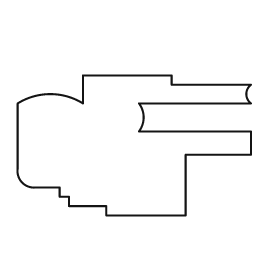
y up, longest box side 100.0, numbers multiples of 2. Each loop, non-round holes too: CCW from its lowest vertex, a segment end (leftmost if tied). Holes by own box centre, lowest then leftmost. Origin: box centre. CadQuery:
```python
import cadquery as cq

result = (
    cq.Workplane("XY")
    .moveTo(-12.0, -30.0)
    .lineTo(22.0, -30.0)
    .lineTo(22.0, -4.0)
    .lineTo(50.0, -4.0)
    .lineTo(50.0, 6.0)
    .lineTo(2.0, 6.0)
    .threePointArc((4.0, 12.0), (2.0, 18.0))
    .lineTo(50.0, 18.0)
    .threePointArc((48.0, 22.0), (50.0, 26.0))
    .lineTo(16.0, 26.0)
    .lineTo(16.0, 30.0)
    .lineTo(-22.0, 30.0)
    .lineTo(-22.0, 18.0)
    .threePointArc((-36.0, 22.0), (-50.0, 18.0))
    .lineTo(-50.0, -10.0)
    .threePointArc((-48.0, -16.0), (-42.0, -18.0))
    .lineTo(-32.0, -18.0)
    .lineTo(-32.0, -22.0)
    .lineTo(-28.0, -22.0)
    .lineTo(-28.0, -26.0)
    .lineTo(-12.0, -26.0)
    .close()
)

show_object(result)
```